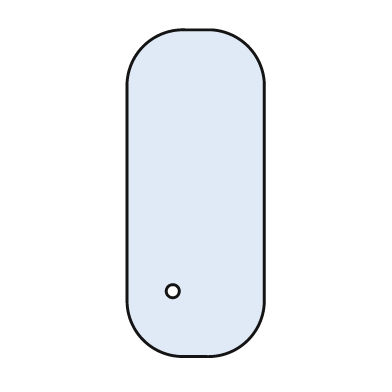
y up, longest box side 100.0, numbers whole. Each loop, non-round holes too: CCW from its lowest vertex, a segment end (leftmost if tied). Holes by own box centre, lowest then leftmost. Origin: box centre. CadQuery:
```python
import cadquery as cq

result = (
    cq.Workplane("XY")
    .moveTo(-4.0, -50.0)
    .lineTo(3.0, -50.0)
    .threePointArc((16.0, -45.0), (21.0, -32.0))
    .lineTo(21.0, 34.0)
    .threePointArc((16.0, 45.0), (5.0, 50.0))
    .lineTo(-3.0, 50.0)
    .threePointArc((-16.0, 45.0), (-21.0, 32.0))
    .lineTo(-21.0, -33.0)
    .threePointArc((-16.0, -45.0), (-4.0, -50.0))
    .close()
    .moveTo(-7.0, -30.0)
    .circle(2.0)
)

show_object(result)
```